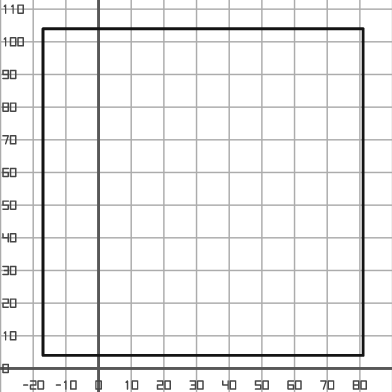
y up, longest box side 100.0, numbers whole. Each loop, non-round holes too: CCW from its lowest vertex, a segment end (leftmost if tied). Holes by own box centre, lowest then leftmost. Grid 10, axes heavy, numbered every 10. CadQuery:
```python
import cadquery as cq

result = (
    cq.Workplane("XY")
    .moveTo(-17.0, 4.0)
    .lineTo(81.0, 4.0)
    .lineTo(81.0, 104.0)
    .lineTo(-17.0, 104.0)
    .close()
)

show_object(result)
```